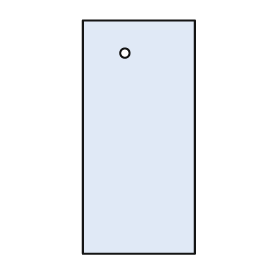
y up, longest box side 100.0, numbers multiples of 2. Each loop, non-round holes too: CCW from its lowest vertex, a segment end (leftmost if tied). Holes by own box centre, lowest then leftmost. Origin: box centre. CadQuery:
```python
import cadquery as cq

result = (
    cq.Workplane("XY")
    .moveTo(-24.0, -50.0)
    .lineTo(24.0, -50.0)
    .lineTo(24.0, 50.0)
    .lineTo(-24.0, 50.0)
    .close()
    .moveTo(-6.0, 36.0)
    .circle(2.0)
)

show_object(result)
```